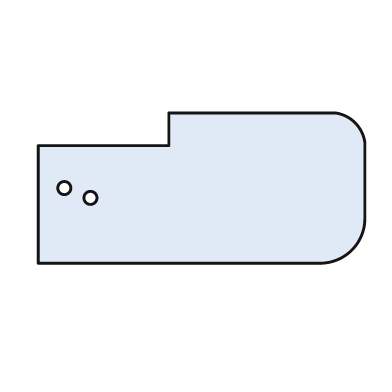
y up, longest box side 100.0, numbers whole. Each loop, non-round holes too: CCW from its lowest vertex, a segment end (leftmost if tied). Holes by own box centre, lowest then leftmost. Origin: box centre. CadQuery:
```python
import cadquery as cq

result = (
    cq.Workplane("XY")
    .moveTo(-50.0, -23.0)
    .lineTo(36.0, -23.0)
    .threePointArc((46.0, -19.0), (50.0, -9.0))
    .lineTo(50.0, 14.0)
    .threePointArc((47.0, 20.0), (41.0, 23.0))
    .lineTo(-10.0, 23.0)
    .lineTo(-10.0, 13.0)
    .lineTo(-50.0, 13.0)
    .close()
    .moveTo(-34.0, -3.0)
    .circle(2.0)
    .moveTo(-42.0, 0.0)
    .circle(2.0)
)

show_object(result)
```